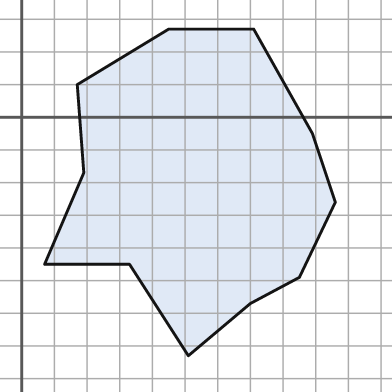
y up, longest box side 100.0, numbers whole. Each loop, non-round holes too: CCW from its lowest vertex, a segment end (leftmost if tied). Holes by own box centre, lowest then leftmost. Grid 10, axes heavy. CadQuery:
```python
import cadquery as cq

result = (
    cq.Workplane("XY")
    .moveTo(51.0, -73.0)
    .lineTo(70.0, -57.0)
    .lineTo(85.0, -49.0)
    .lineTo(96.0, -26.0)
    .lineTo(89.0, -5.0)
    .lineTo(71.0, 27.0)
    .lineTo(45.0, 27.0)
    .lineTo(17.0, 10.0)
    .lineTo(19.0, -17.0)
    .lineTo(7.0, -45.0)
    .lineTo(33.0, -45.0)
    .close()
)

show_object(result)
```